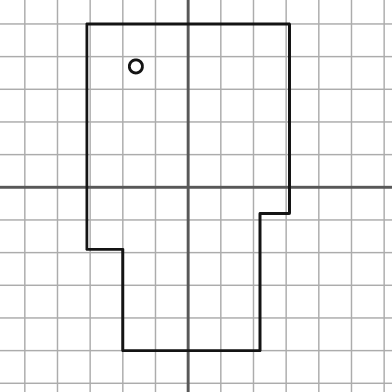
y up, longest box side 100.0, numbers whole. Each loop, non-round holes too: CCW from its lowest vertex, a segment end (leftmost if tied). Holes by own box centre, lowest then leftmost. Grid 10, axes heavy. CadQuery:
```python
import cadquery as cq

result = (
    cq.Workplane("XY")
    .moveTo(-20.0, -50.0)
    .lineTo(22.0, -50.0)
    .lineTo(22.0, -8.0)
    .lineTo(31.0, -8.0)
    .lineTo(31.0, 50.0)
    .lineTo(-31.0, 50.0)
    .lineTo(-31.0, -19.0)
    .lineTo(-20.0, -19.0)
    .close()
    .moveTo(-16.0, 37.0)
    .circle(2.0)
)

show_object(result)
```